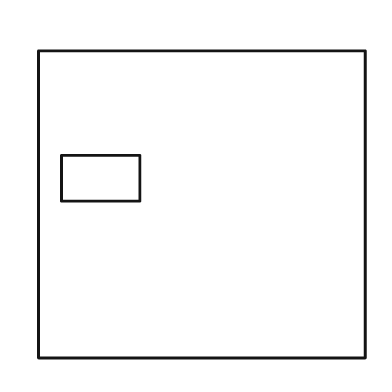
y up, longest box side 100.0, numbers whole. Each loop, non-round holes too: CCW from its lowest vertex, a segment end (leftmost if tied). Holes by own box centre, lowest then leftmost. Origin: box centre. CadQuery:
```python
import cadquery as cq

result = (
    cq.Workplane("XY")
    .moveTo(-50.0, -47.0)
    .lineTo(50.0, -47.0)
    .lineTo(50.0, 47.0)
    .lineTo(-50.0, 47.0)
    .close()
    .moveTo(-43.0, 1.0)
    .lineTo(-19.0, 1.0)
    .lineTo(-19.0, 15.0)
    .lineTo(-43.0, 15.0)
    .close()
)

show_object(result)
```